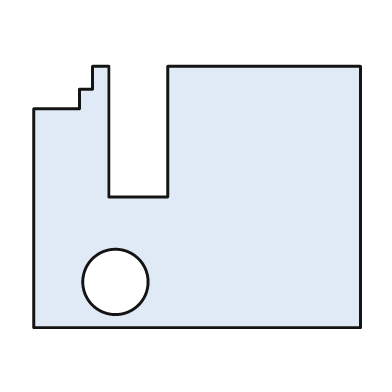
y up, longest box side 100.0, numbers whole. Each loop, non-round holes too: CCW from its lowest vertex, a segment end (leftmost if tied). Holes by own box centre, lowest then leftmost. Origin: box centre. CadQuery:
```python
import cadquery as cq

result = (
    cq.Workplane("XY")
    .moveTo(-50.0, -40.0)
    .lineTo(50.0, -40.0)
    .lineTo(50.0, 40.0)
    .lineTo(-9.0, 40.0)
    .lineTo(-9.0, 0.0)
    .lineTo(-27.0, 0.0)
    .lineTo(-27.0, 40.0)
    .lineTo(-32.0, 40.0)
    .lineTo(-32.0, 33.0)
    .lineTo(-36.0, 33.0)
    .lineTo(-36.0, 27.0)
    .lineTo(-50.0, 27.0)
    .close()
    .moveTo(-25.0, -26.0)
    .circle(10.0)
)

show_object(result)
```